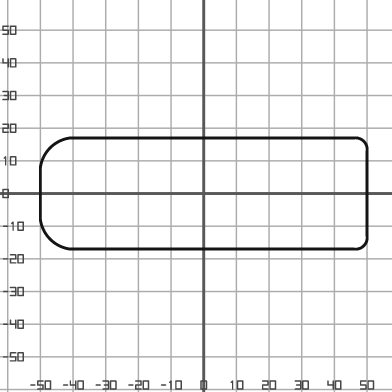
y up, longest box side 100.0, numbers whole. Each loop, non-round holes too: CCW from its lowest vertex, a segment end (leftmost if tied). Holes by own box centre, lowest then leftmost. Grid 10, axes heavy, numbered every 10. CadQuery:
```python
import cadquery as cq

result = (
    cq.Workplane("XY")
    .moveTo(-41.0, -17.0)
    .lineTo(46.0, -17.0)
    .threePointArc((49.0, -16.0), (50.0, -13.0))
    .lineTo(50.0, 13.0)
    .threePointArc((49.0, 16.0), (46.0, 17.0))
    .lineTo(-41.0, 17.0)
    .threePointArc((-47.0, 14.0), (-50.0, 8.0))
    .lineTo(-50.0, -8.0)
    .threePointArc((-47.0, -14.0), (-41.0, -17.0))
    .close()
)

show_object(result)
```